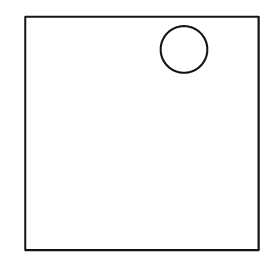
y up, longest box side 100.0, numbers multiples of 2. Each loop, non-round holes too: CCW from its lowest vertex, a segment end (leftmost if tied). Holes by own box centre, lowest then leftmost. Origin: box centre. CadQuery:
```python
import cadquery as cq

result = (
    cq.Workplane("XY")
    .moveTo(-50.0, -50.0)
    .lineTo(50.0, -50.0)
    .lineTo(50.0, 50.0)
    .lineTo(-50.0, 50.0)
    .close()
    .moveTo(18.0, 36.0)
    .circle(10.0)
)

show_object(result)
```